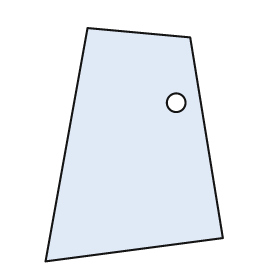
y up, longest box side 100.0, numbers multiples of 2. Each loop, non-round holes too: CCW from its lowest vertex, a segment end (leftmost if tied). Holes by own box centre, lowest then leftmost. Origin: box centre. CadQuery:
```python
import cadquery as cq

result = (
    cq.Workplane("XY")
    .moveTo(-38.0, -50.0)
    .lineTo(38.0, -40.0)
    .lineTo(24.0, 46.0)
    .lineTo(-20.0, 50.0)
    .close()
    .moveTo(18.0, 18.0)
    .circle(4.0)
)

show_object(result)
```